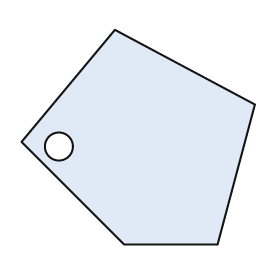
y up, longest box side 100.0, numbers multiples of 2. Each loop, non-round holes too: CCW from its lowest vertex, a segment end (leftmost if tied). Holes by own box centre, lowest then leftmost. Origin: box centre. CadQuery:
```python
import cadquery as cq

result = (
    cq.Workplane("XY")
    .moveTo(-6.0, -46.0)
    .lineTo(34.0, -46.0)
    .lineTo(50.0, 14.0)
    .lineTo(-10.0, 46.0)
    .lineTo(-50.0, -2.0)
    .close()
    .moveTo(-34.0, -4.0)
    .circle(6.0)
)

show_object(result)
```